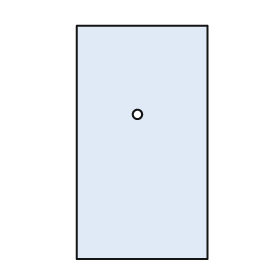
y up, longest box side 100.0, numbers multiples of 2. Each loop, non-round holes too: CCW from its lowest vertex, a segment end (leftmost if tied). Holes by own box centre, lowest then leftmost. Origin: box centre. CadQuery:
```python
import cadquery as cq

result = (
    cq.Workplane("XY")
    .moveTo(-28.0, -50.0)
    .lineTo(28.0, -50.0)
    .lineTo(28.0, 50.0)
    .lineTo(-28.0, 50.0)
    .close()
    .moveTo(-2.0, 12.0)
    .circle(2.0)
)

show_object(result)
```